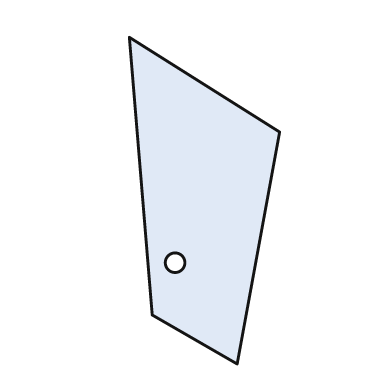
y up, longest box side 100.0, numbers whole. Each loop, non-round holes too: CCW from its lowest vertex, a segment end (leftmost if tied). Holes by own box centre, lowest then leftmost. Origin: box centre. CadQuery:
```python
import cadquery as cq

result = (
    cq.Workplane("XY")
    .moveTo(10.0, -50.0)
    .lineTo(23.0, 21.0)
    .lineTo(-23.0, 50.0)
    .lineTo(-16.0, -35.0)
    .close()
    .moveTo(-9.0, -19.0)
    .circle(3.0)
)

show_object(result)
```